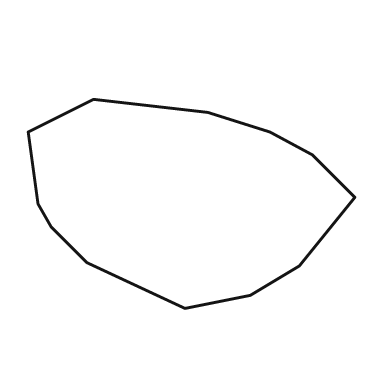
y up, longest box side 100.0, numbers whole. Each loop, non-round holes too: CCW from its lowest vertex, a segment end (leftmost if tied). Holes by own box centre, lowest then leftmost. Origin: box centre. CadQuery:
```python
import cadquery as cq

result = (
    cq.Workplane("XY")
    .moveTo(-2.0, -32.0)
    .lineTo(18.0, -28.0)
    .lineTo(33.0, -19.0)
    .lineTo(50.0, 2.0)
    .lineTo(37.0, 15.0)
    .lineTo(24.0, 22.0)
    .lineTo(5.0, 28.0)
    .lineTo(-30.0, 32.0)
    .lineTo(-50.0, 22.0)
    .lineTo(-47.0, 0.0)
    .lineTo(-43.0, -7.0)
    .lineTo(-32.0, -18.0)
    .close()
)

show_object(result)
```